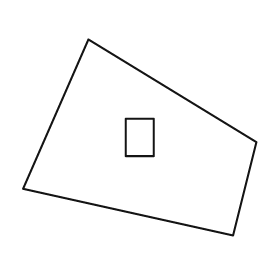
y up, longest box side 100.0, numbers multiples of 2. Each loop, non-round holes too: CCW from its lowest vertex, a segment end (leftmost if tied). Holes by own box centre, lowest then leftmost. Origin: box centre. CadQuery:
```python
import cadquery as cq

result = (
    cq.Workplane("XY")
    .moveTo(40.0, -42.0)
    .lineTo(50.0, -2.0)
    .lineTo(-22.0, 42.0)
    .lineTo(-50.0, -22.0)
    .close()
    .moveTo(-6.0, -8.0)
    .lineTo(6.0, -8.0)
    .lineTo(6.0, 8.0)
    .lineTo(-6.0, 8.0)
    .close()
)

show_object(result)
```